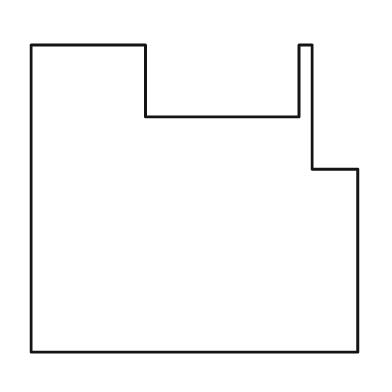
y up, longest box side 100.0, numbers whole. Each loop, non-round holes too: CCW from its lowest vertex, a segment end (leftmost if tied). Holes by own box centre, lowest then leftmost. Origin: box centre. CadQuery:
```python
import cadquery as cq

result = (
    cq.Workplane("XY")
    .moveTo(-50.0, -47.0)
    .lineTo(50.0, -47.0)
    .lineTo(50.0, 9.0)
    .lineTo(36.0, 9.0)
    .lineTo(36.0, 47.0)
    .lineTo(32.0, 47.0)
    .lineTo(32.0, 25.0)
    .lineTo(-15.0, 25.0)
    .lineTo(-15.0, 47.0)
    .lineTo(-50.0, 47.0)
    .close()
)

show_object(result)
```